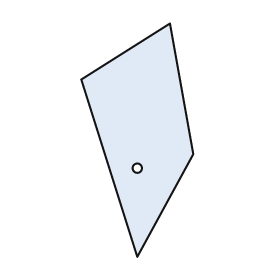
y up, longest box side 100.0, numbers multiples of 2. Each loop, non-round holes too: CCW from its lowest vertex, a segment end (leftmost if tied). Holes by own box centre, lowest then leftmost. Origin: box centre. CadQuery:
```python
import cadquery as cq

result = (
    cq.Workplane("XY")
    .moveTo(0.0, -50.0)
    .lineTo(24.0, -6.0)
    .lineTo(14.0, 50.0)
    .lineTo(-24.0, 26.0)
    .close()
    .moveTo(0.0, -12.0)
    .circle(2.0)
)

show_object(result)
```